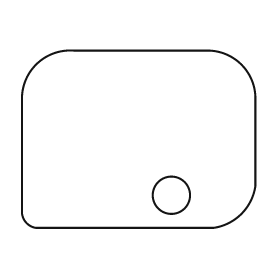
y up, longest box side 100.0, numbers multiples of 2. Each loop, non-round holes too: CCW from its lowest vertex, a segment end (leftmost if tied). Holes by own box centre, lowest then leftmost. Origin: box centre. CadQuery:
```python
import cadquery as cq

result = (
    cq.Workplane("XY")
    .moveTo(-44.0, -38.0)
    .lineTo(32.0, -38.0)
    .threePointArc((44.0, -32.0), (50.0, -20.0))
    .lineTo(50.0, 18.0)
    .threePointArc((44.0, 32.0), (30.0, 38.0))
    .lineTo(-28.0, 38.0)
    .threePointArc((-44.0, 32.0), (-50.0, 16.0))
    .lineTo(-50.0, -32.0)
    .threePointArc((-48.0, -36.0), (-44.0, -38.0))
    .close()
    .moveTo(14.0, -24.0)
    .circle(8.0)
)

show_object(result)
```